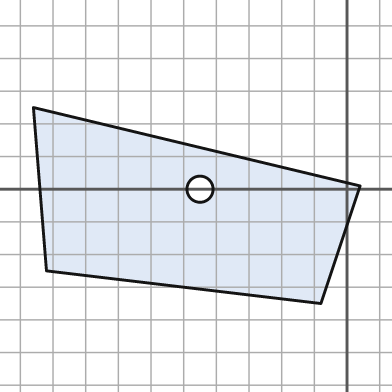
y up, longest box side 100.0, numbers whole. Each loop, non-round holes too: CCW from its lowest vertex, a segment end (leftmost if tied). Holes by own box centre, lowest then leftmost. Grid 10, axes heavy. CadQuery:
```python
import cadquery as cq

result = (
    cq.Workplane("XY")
    .moveTo(-8.0, -35.0)
    .lineTo(4.0, 1.0)
    .lineTo(-96.0, 25.0)
    .lineTo(-92.0, -25.0)
    .close()
    .moveTo(-45.0, 0.0)
    .circle(4.0)
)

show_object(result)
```